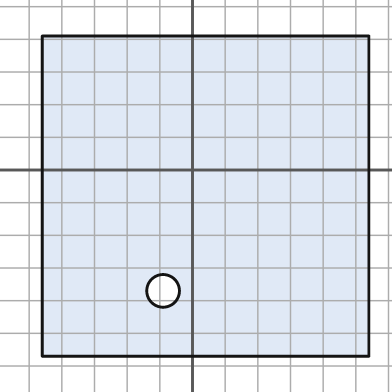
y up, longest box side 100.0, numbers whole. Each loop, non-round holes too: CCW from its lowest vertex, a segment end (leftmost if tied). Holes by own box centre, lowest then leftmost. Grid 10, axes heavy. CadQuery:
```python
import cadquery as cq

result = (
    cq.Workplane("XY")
    .moveTo(-46.0, -57.0)
    .lineTo(54.0, -57.0)
    .lineTo(54.0, 41.0)
    .lineTo(-46.0, 41.0)
    .close()
    .moveTo(-9.0, -37.0)
    .circle(5.0)
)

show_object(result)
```